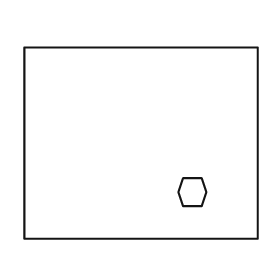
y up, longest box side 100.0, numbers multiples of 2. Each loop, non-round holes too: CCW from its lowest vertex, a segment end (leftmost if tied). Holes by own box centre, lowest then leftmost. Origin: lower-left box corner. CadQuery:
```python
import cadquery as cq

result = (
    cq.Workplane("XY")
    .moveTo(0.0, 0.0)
    .lineTo(100.0, 0.0)
    .lineTo(100.0, 82.0)
    .lineTo(0.0, 82.0)
    .close()
    .moveTo(68.0, 14.0)
    .lineTo(76.0, 14.0)
    .lineTo(78.0, 20.0)
    .lineTo(76.0, 26.0)
    .lineTo(68.0, 26.0)
    .lineTo(66.0, 20.0)
    .close()
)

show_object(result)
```